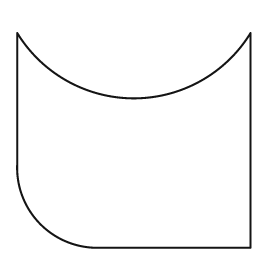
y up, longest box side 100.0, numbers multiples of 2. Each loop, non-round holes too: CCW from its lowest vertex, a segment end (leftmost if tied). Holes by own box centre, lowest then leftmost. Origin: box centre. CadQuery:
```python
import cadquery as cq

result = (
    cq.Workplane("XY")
    .moveTo(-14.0, -46.0)
    .lineTo(50.0, -46.0)
    .lineTo(50.0, 46.0)
    .threePointArc((0.0, 18.0), (-50.0, 46.0))
    .lineTo(-50.0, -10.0)
    .threePointArc((-40.0, -36.0), (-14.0, -46.0))
    .close()
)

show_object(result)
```